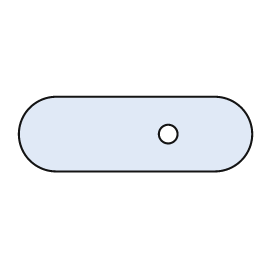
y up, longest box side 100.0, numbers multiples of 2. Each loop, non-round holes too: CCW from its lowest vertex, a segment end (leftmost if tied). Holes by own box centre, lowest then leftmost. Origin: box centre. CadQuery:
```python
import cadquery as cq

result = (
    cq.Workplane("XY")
    .moveTo(-34.0, -16.0)
    .lineTo(34.0, -16.0)
    .threePointArc((50.0, 0.0), (34.0, 16.0))
    .lineTo(-34.0, 16.0)
    .threePointArc((-50.0, 0.0), (-34.0, -16.0))
    .close()
    .moveTo(14.0, 0.0)
    .circle(4.0)
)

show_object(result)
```